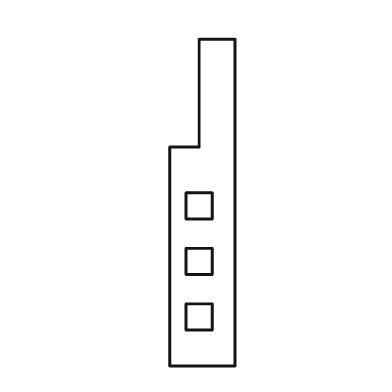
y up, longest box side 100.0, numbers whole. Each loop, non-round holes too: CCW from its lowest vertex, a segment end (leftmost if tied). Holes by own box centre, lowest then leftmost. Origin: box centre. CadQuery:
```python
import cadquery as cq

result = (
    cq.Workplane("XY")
    .moveTo(-10.0, -50.0)
    .lineTo(10.0, -50.0)
    .lineTo(10.0, 50.0)
    .lineTo(-1.0, 50.0)
    .lineTo(-1.0, 17.0)
    .lineTo(-10.0, 17.0)
    .close()
    .moveTo(-5.0, -39.0)
    .lineTo(3.0, -39.0)
    .lineTo(3.0, -31.0)
    .lineTo(-5.0, -31.0)
    .close()
    .moveTo(-5.0, -22.0)
    .lineTo(3.0, -22.0)
    .lineTo(3.0, -14.0)
    .lineTo(-5.0, -14.0)
    .close()
    .moveTo(-5.0, -5.0)
    .lineTo(3.0, -5.0)
    .lineTo(3.0, 3.0)
    .lineTo(-5.0, 3.0)
    .close()
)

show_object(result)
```